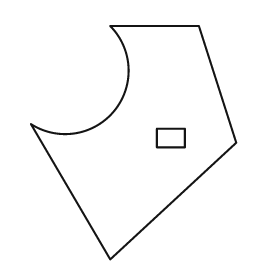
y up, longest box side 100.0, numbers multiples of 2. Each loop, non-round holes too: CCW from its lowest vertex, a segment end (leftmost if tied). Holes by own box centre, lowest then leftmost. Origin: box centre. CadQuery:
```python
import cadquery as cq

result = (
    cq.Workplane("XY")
    .moveTo(-10.0, -50.0)
    .lineTo(44.0, 0.0)
    .lineTo(28.0, 50.0)
    .lineTo(-10.0, 50.0)
    .threePointArc((-8.0, 14.0), (-44.0, 8.0))
    .close()
    .moveTo(10.0, -2.0)
    .lineTo(22.0, -2.0)
    .lineTo(22.0, 6.0)
    .lineTo(10.0, 6.0)
    .close()
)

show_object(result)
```